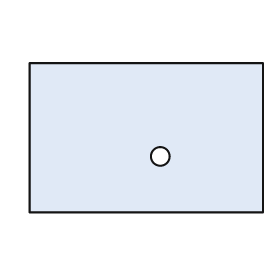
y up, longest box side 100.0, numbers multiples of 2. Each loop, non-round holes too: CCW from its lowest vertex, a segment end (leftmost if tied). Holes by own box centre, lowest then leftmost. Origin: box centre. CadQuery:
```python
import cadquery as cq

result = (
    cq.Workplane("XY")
    .moveTo(-50.0, -32.0)
    .lineTo(50.0, -32.0)
    .lineTo(50.0, 32.0)
    .lineTo(-50.0, 32.0)
    .close()
    .moveTo(6.0, -8.0)
    .circle(4.0)
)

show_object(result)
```